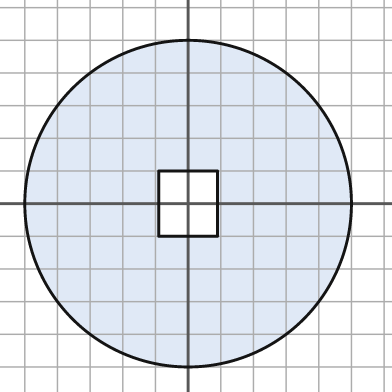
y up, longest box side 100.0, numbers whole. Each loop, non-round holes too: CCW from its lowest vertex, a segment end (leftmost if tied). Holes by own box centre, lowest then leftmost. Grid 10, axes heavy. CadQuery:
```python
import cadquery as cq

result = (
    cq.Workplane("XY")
    .moveTo(0.0, 0.0)
    .circle(50.0)
    .moveTo(-9.0, -10.0)
    .lineTo(9.0, -10.0)
    .lineTo(9.0, 10.0)
    .lineTo(-9.0, 10.0)
    .close()
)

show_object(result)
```